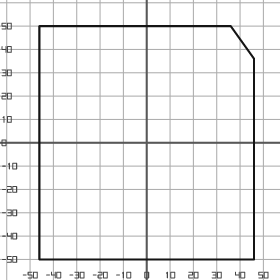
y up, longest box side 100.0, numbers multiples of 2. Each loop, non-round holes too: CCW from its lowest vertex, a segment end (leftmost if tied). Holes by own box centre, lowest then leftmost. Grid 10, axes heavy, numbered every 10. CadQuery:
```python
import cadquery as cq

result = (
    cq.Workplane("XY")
    .moveTo(-46.0, -50.0)
    .lineTo(46.0, -50.0)
    .lineTo(46.0, 36.0)
    .lineTo(36.0, 50.0)
    .lineTo(-46.0, 50.0)
    .close()
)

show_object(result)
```